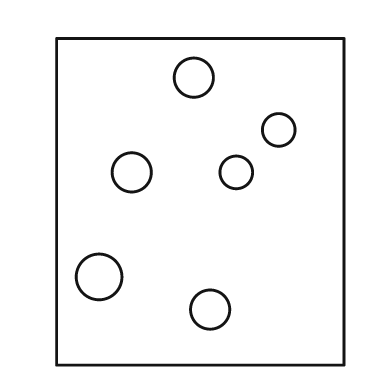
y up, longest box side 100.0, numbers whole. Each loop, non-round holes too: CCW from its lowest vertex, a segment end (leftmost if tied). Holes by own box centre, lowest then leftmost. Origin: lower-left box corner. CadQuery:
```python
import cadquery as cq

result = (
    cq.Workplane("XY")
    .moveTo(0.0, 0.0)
    .lineTo(88.0, 0.0)
    .lineTo(88.0, 100.0)
    .lineTo(0.0, 100.0)
    .close()
    .moveTo(47.0, 17.0)
    .circle(6.0)
    .moveTo(13.0, 27.0)
    .circle(7.0)
    .moveTo(23.0, 59.0)
    .circle(6.0)
    .moveTo(55.0, 59.0)
    .circle(5.0)
    .moveTo(68.0, 72.0)
    .circle(5.0)
    .moveTo(42.0, 88.0)
    .circle(6.0)
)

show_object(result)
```